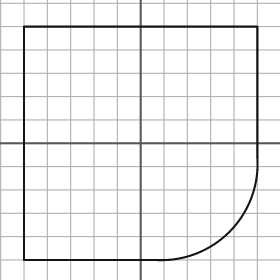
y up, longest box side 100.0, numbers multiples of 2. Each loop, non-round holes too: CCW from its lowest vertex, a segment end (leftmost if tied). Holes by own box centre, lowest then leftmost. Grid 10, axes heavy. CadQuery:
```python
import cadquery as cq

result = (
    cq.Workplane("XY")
    .moveTo(-50.0, -50.0)
    .lineTo(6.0, -50.0)
    .threePointArc((38.0, -38.0), (50.0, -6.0))
    .lineTo(50.0, 50.0)
    .lineTo(-50.0, 50.0)
    .close()
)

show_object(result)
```